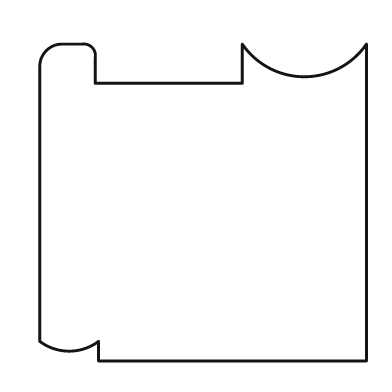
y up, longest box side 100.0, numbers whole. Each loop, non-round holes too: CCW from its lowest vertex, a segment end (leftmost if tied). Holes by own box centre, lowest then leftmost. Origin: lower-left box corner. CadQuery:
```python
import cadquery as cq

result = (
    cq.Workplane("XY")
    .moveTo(18.0, 0.0)
    .lineTo(100.0, 0.0)
    .lineTo(100.0, 97.0)
    .threePointArc((81.0, 87.0), (62.0, 97.0))
    .lineTo(62.0, 85.0)
    .lineTo(17.0, 85.0)
    .lineTo(17.0, 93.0)
    .threePointArc((16.0, 96.0), (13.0, 97.0))
    .lineTo(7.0, 97.0)
    .threePointArc((2.0, 95.0), (0.0, 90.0))
    .lineTo(0.0, 6.0)
    .threePointArc((9.0, 3.0), (18.0, 6.0))
    .close()
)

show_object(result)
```